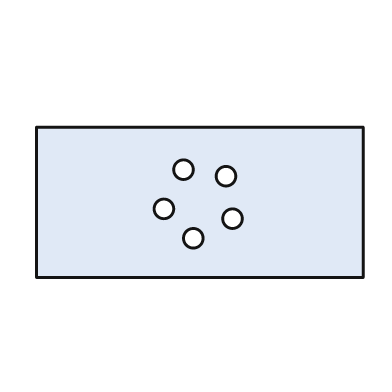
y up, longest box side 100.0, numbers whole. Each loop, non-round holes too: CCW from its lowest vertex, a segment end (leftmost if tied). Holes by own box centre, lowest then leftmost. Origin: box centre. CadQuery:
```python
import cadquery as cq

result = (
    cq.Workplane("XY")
    .moveTo(-50.0, -23.0)
    .lineTo(50.0, -23.0)
    .lineTo(50.0, 23.0)
    .lineTo(-50.0, 23.0)
    .close()
    .moveTo(-2.0, -11.0)
    .circle(3.0)
    .moveTo(10.0, -5.0)
    .circle(3.0)
    .moveTo(-11.0, -2.0)
    .circle(3.0)
    .moveTo(8.0, 8.0)
    .circle(3.0)
    .moveTo(-5.0, 10.0)
    .circle(3.0)
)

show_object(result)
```